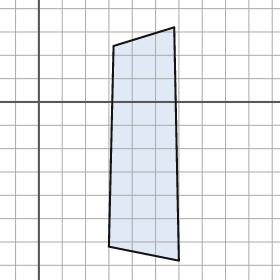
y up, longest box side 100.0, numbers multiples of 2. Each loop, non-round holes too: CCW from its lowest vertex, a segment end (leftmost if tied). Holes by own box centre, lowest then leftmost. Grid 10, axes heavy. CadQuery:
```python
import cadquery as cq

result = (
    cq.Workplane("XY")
    .moveTo(60.0, -68.0)
    .lineTo(58.0, 32.0)
    .lineTo(32.0, 24.0)
    .lineTo(30.0, -62.0)
    .close()
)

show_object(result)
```